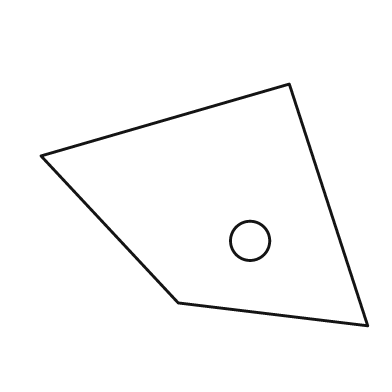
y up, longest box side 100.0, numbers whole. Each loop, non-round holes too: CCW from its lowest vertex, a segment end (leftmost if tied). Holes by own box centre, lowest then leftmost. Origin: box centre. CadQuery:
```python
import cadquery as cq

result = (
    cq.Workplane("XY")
    .moveTo(50.0, -37.0)
    .lineTo(26.0, 37.0)
    .lineTo(-50.0, 15.0)
    .lineTo(-8.0, -30.0)
    .close()
    .moveTo(14.0, -11.0)
    .circle(6.0)
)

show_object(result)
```